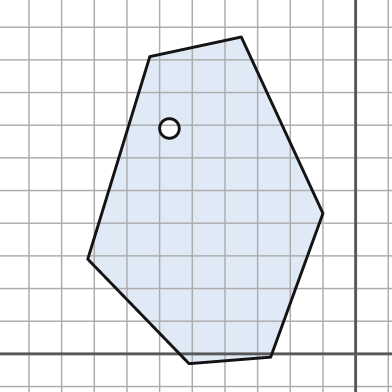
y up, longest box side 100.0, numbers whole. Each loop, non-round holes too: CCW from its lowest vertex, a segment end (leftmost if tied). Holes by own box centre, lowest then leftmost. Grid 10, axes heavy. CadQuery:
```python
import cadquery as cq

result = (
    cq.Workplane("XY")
    .moveTo(-51.0, -3.0)
    .lineTo(-26.0, -1.0)
    .lineTo(-10.0, 43.0)
    .lineTo(-35.0, 97.0)
    .lineTo(-63.0, 91.0)
    .lineTo(-82.0, 29.0)
    .close()
    .moveTo(-57.0, 69.0)
    .circle(3.0)
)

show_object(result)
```